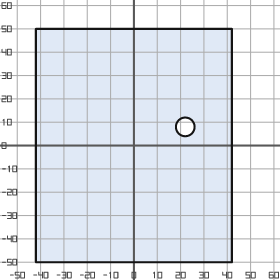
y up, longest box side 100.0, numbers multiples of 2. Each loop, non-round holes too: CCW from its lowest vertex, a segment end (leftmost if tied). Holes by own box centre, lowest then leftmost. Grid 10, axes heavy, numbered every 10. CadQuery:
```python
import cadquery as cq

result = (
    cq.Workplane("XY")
    .moveTo(-42.0, -50.0)
    .lineTo(42.0, -50.0)
    .lineTo(42.0, 50.0)
    .lineTo(-42.0, 50.0)
    .close()
    .moveTo(22.0, 8.0)
    .circle(4.0)
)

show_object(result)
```